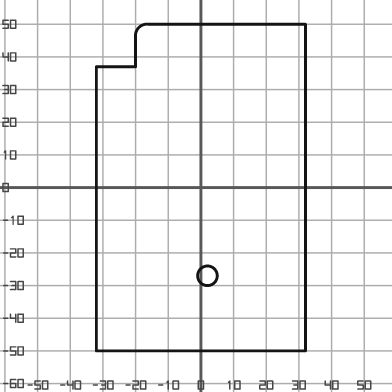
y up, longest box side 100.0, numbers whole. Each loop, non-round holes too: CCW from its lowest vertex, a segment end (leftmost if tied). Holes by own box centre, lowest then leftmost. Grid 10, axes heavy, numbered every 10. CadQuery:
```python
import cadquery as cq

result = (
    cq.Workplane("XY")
    .moveTo(-32.0, -50.0)
    .lineTo(32.0, -50.0)
    .lineTo(32.0, 50.0)
    .lineTo(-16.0, 50.0)
    .threePointArc((-19.0, 49.0), (-20.0, 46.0))
    .lineTo(-20.0, 37.0)
    .lineTo(-32.0, 37.0)
    .close()
    .moveTo(2.0, -27.0)
    .circle(3.0)
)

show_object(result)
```